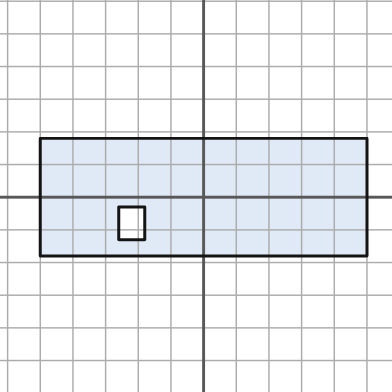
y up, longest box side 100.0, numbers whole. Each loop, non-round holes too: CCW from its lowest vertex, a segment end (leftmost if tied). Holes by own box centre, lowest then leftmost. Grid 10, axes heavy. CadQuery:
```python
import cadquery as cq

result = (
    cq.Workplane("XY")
    .moveTo(-50.0, -18.0)
    .lineTo(50.0, -18.0)
    .lineTo(50.0, 18.0)
    .lineTo(-50.0, 18.0)
    .close()
    .moveTo(-26.0, -13.0)
    .lineTo(-18.0, -13.0)
    .lineTo(-18.0, -3.0)
    .lineTo(-26.0, -3.0)
    .close()
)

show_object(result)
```